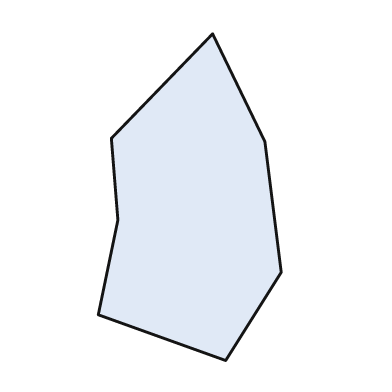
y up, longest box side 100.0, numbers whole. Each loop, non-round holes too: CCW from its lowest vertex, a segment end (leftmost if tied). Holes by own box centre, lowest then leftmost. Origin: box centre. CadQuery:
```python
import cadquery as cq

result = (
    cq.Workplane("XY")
    .moveTo(11.0, -50.0)
    .lineTo(28.0, -23.0)
    .lineTo(23.0, 17.0)
    .lineTo(7.0, 50.0)
    .lineTo(-24.0, 18.0)
    .lineTo(-22.0, -7.0)
    .lineTo(-28.0, -36.0)
    .close()
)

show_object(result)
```